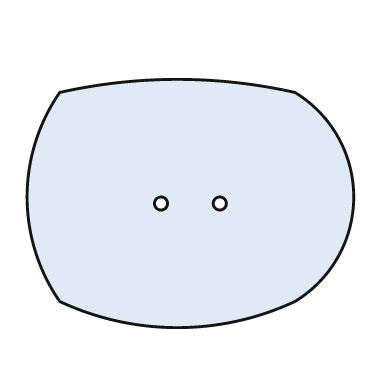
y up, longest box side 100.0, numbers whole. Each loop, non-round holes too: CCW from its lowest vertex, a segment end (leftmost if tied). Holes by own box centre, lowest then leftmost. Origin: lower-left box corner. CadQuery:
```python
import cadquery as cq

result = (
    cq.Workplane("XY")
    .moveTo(10.0, 8.0)
    .threePointArc((46.0, 0.0), (82.0, 8.0))
    .threePointArc((100.0, 40.0), (82.0, 72.0))
    .threePointArc((46.0, 76.0), (10.0, 72.0))
    .threePointArc((0.0, 40.0), (10.0, 8.0))
    .close()
    .moveTo(41.0, 38.0)
    .circle(2.0)
    .moveTo(59.0, 38.0)
    .circle(2.0)
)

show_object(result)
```